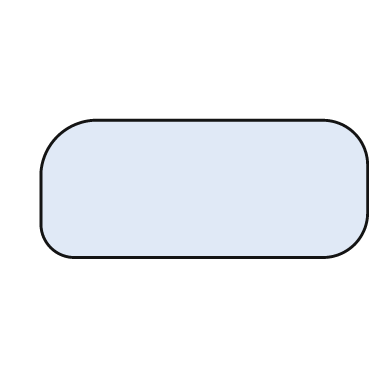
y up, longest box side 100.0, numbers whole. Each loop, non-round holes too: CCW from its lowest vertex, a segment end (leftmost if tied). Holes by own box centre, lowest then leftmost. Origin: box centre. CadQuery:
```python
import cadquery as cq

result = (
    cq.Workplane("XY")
    .moveTo(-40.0, -21.0)
    .lineTo(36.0, -21.0)
    .threePointArc((46.0, -17.0), (50.0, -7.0))
    .lineTo(50.0, 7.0)
    .threePointArc((46.0, 17.0), (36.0, 21.0))
    .lineTo(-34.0, 21.0)
    .threePointArc((-45.0, 16.0), (-50.0, 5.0))
    .lineTo(-50.0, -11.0)
    .threePointArc((-47.0, -18.0), (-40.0, -21.0))
    .close()
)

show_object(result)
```